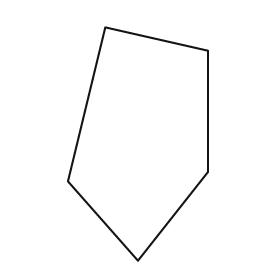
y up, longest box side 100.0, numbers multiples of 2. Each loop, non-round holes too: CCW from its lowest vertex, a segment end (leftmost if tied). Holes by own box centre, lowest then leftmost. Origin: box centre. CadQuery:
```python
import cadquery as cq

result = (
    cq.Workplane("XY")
    .moveTo(0.0, -50.0)
    .lineTo(30.0, -12.0)
    .lineTo(30.0, 40.0)
    .lineTo(-14.0, 50.0)
    .lineTo(-30.0, -16.0)
    .close()
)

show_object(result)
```